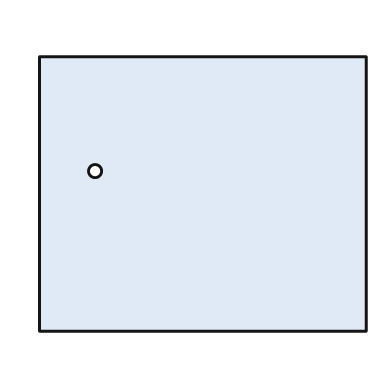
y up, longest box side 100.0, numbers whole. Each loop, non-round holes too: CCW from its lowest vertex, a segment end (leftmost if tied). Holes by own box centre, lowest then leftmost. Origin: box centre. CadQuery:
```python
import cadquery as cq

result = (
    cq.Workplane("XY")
    .moveTo(-50.0, -42.0)
    .lineTo(50.0, -42.0)
    .lineTo(50.0, 42.0)
    .lineTo(-50.0, 42.0)
    .close()
    .moveTo(-33.0, 7.0)
    .circle(2.0)
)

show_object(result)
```